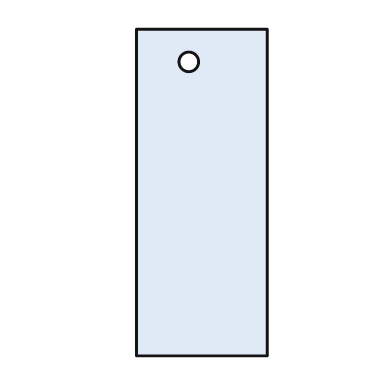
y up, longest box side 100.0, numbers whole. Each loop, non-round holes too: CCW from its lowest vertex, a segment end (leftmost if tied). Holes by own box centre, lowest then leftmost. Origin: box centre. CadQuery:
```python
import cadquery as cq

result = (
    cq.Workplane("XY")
    .moveTo(-20.0, -50.0)
    .lineTo(20.0, -50.0)
    .lineTo(20.0, 50.0)
    .lineTo(-20.0, 50.0)
    .close()
    .moveTo(-4.0, 40.0)
    .circle(3.0)
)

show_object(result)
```